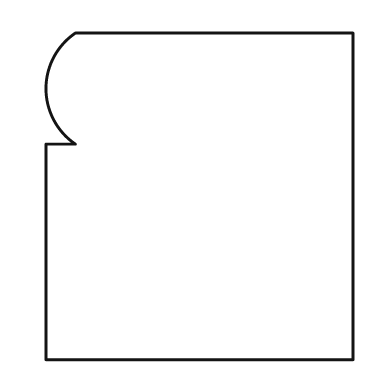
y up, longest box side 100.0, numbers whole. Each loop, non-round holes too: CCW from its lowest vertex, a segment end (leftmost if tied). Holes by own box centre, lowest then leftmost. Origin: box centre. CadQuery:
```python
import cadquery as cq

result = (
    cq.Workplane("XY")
    .moveTo(-47.0, -50.0)
    .lineTo(47.0, -50.0)
    .lineTo(47.0, 50.0)
    .lineTo(-38.0, 50.0)
    .threePointArc((-47.0, 33.0), (-38.0, 16.0))
    .lineTo(-47.0, 16.0)
    .close()
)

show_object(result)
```